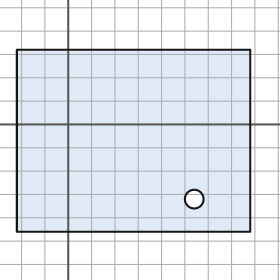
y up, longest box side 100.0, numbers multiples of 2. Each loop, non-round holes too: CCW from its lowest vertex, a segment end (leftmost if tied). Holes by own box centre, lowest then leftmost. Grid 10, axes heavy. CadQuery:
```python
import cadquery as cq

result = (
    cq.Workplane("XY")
    .moveTo(-22.0, -46.0)
    .lineTo(78.0, -46.0)
    .lineTo(78.0, 32.0)
    .lineTo(-22.0, 32.0)
    .close()
    .moveTo(54.0, -32.0)
    .circle(4.0)
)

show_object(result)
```